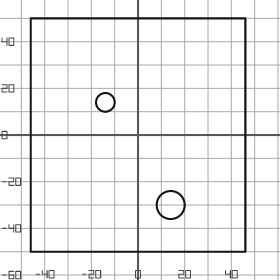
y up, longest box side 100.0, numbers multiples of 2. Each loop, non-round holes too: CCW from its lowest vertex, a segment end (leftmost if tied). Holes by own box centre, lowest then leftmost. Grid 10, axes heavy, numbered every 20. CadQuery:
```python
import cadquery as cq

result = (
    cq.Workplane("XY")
    .moveTo(-46.0, -50.0)
    .lineTo(46.0, -50.0)
    .lineTo(46.0, 50.0)
    .lineTo(-46.0, 50.0)
    .close()
    .moveTo(14.0, -30.0)
    .circle(6.0)
    .moveTo(-14.0, 14.0)
    .circle(4.0)
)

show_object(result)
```